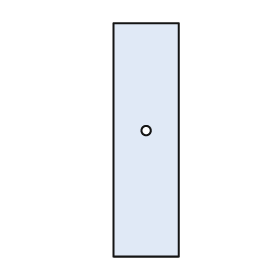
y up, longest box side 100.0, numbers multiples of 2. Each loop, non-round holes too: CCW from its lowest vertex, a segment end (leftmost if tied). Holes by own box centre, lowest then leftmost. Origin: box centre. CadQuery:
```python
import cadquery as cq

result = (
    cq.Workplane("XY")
    .moveTo(-14.0, -50.0)
    .lineTo(14.0, -50.0)
    .lineTo(14.0, 50.0)
    .lineTo(-14.0, 50.0)
    .close()
    .moveTo(0.0, 4.0)
    .circle(2.0)
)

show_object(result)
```